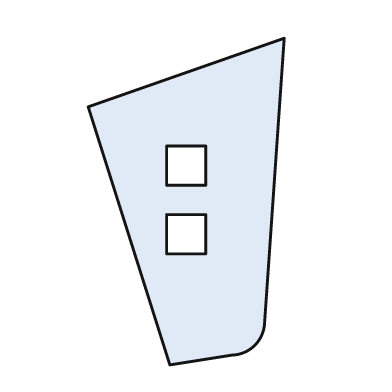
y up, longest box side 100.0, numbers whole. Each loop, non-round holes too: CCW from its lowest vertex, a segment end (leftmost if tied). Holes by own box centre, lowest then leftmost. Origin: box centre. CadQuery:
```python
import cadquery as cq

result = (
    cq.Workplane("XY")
    .moveTo(-5.0, -50.0)
    .lineTo(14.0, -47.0)
    .threePointArc((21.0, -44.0), (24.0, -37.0))
    .lineTo(30.0, 50.0)
    .lineTo(-30.0, 29.0)
    .close()
    .moveTo(-6.0, -16.0)
    .lineTo(6.0, -16.0)
    .lineTo(6.0, -4.0)
    .lineTo(-6.0, -4.0)
    .close()
    .moveTo(-6.0, 5.0)
    .lineTo(6.0, 5.0)
    .lineTo(6.0, 17.0)
    .lineTo(-6.0, 17.0)
    .close()
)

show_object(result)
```